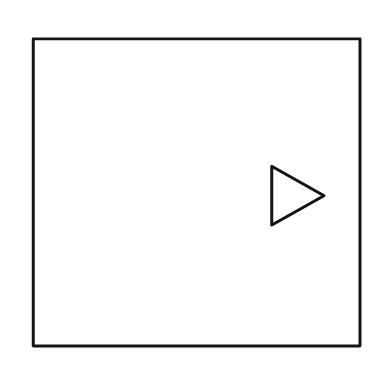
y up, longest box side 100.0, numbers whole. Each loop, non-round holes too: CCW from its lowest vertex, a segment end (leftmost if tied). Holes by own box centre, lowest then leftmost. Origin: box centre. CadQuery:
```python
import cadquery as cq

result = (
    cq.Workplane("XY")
    .moveTo(-50.0, -47.0)
    .lineTo(50.0, -47.0)
    .lineTo(50.0, 47.0)
    .lineTo(-50.0, 47.0)
    .close()
    .moveTo(23.0, -10.0)
    .lineTo(39.0, -1.0)
    .lineTo(23.0, 8.0)
    .close()
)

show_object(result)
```